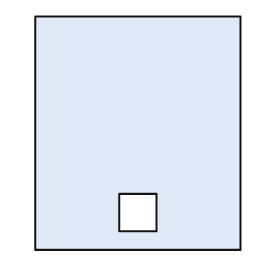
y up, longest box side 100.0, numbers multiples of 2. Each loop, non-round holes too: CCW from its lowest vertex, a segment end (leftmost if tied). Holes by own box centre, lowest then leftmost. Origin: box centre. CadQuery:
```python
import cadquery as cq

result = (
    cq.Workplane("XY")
    .moveTo(-44.0, -50.0)
    .lineTo(44.0, -50.0)
    .lineTo(44.0, 50.0)
    .lineTo(-44.0, 50.0)
    .close()
    .moveTo(-8.0, -42.0)
    .lineTo(8.0, -42.0)
    .lineTo(8.0, -26.0)
    .lineTo(-8.0, -26.0)
    .close()
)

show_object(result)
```